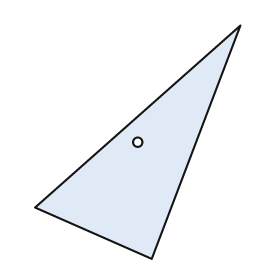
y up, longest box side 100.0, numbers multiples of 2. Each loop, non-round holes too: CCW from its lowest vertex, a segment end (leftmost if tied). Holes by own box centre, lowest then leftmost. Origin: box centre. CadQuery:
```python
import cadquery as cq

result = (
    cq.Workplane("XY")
    .moveTo(6.0, -50.0)
    .lineTo(44.0, 50.0)
    .lineTo(-44.0, -28.0)
    .close()
    .moveTo(0.0, 0.0)
    .circle(2.0)
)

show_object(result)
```